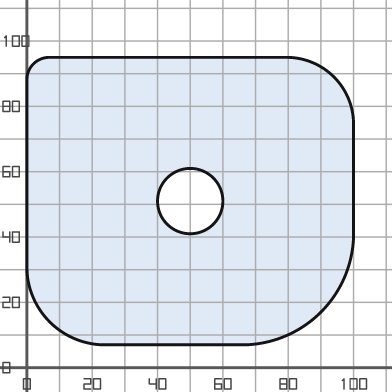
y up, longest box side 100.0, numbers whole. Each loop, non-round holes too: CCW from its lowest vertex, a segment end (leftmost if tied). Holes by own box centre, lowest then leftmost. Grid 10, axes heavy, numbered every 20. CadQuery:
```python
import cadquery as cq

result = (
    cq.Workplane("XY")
    .moveTo(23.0, 7.0)
    .lineTo(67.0, 7.0)
    .threePointArc((90.0, 17.0), (100.0, 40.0))
    .lineTo(100.0, 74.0)
    .threePointArc((94.0, 89.0), (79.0, 95.0))
    .lineTo(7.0, 95.0)
    .threePointArc((2.0, 93.0), (0.0, 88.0))
    .lineTo(0.0, 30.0)
    .threePointArc((7.0, 14.0), (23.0, 7.0))
    .close()
    .moveTo(50.0, 51.0)
    .circle(10.0)
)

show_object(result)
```